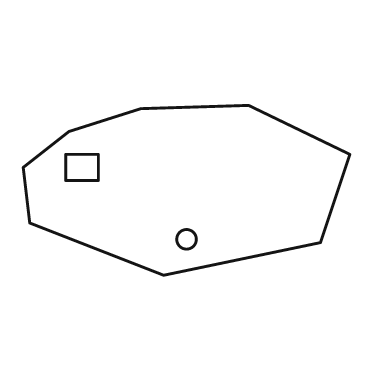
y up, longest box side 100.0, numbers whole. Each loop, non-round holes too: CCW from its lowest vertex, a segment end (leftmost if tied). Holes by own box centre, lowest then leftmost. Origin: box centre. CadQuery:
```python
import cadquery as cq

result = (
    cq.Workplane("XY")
    .moveTo(-7.0, -26.0)
    .lineTo(41.0, -16.0)
    .lineTo(50.0, 11.0)
    .lineTo(19.0, 26.0)
    .lineTo(-14.0, 25.0)
    .lineTo(-36.0, 18.0)
    .lineTo(-50.0, 7.0)
    .lineTo(-48.0, -10.0)
    .close()
    .moveTo(0.0, -15.0)
    .circle(3.0)
    .moveTo(-37.0, 3.0)
    .lineTo(-27.0, 3.0)
    .lineTo(-27.0, 11.0)
    .lineTo(-37.0, 11.0)
    .close()
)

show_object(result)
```